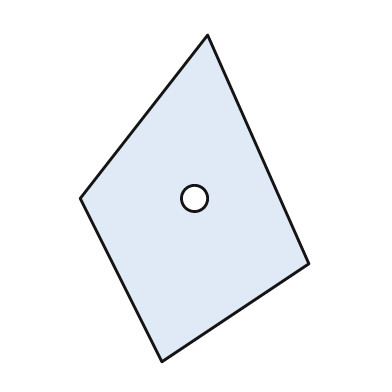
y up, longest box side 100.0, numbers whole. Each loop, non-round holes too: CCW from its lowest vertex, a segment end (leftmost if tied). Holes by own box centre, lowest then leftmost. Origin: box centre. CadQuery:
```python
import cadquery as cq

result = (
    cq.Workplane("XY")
    .moveTo(-10.0, -50.0)
    .lineTo(35.0, -20.0)
    .lineTo(4.0, 50.0)
    .lineTo(-35.0, 0.0)
    .close()
    .moveTo(0.0, 0.0)
    .circle(4.0)
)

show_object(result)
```